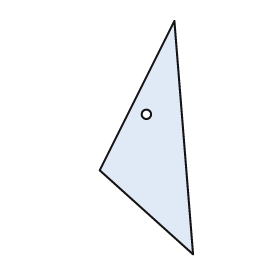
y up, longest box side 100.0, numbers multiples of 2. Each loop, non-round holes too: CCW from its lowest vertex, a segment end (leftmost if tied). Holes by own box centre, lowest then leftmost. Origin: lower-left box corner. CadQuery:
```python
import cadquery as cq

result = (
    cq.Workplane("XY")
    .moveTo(40.0, 0.0)
    .lineTo(32.0, 100.0)
    .lineTo(0.0, 36.0)
    .close()
    .moveTo(20.0, 60.0)
    .circle(2.0)
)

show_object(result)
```